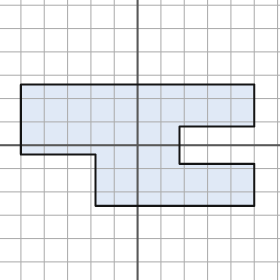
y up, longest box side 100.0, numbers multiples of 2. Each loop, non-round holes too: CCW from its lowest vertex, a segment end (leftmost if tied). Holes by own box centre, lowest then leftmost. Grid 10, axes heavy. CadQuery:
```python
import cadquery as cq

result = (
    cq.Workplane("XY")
    .moveTo(-18.0, -26.0)
    .lineTo(50.0, -26.0)
    .lineTo(50.0, -8.0)
    .lineTo(18.0, -8.0)
    .lineTo(18.0, 8.0)
    .lineTo(50.0, 8.0)
    .lineTo(50.0, 26.0)
    .lineTo(-50.0, 26.0)
    .lineTo(-50.0, -4.0)
    .lineTo(-18.0, -4.0)
    .close()
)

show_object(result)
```